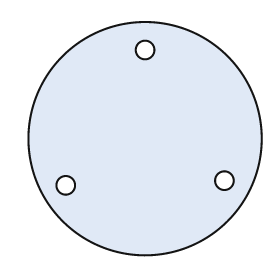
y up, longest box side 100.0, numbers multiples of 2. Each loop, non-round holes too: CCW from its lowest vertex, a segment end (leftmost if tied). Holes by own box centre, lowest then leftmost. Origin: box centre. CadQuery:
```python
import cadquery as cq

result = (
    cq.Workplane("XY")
    .moveTo(0.0, 0.0)
    .circle(50.0)
    .moveTo(-34.0, -20.0)
    .circle(4.0)
    .moveTo(34.0, -18.0)
    .circle(4.0)
    .moveTo(0.0, 38.0)
    .circle(4.0)
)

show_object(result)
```